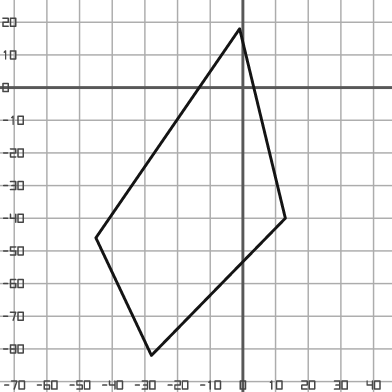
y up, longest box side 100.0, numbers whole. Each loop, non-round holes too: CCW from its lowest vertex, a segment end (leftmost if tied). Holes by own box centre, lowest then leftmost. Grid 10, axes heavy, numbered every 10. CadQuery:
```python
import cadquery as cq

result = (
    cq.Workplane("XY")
    .moveTo(-28.0, -82.0)
    .lineTo(13.0, -40.0)
    .lineTo(-1.0, 18.0)
    .lineTo(-45.0, -46.0)
    .close()
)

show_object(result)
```